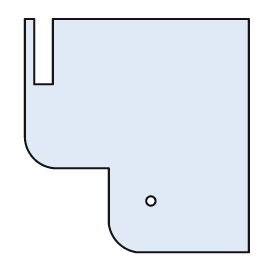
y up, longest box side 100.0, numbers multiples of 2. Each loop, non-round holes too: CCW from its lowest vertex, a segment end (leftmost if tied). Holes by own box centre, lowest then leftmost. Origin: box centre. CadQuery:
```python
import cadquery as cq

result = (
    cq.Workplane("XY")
    .moveTo(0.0, -50.0)
    .lineTo(48.0, -50.0)
    .lineTo(48.0, 50.0)
    .lineTo(-36.0, 50.0)
    .lineTo(-36.0, 22.0)
    .lineTo(-44.0, 22.0)
    .lineTo(-44.0, 50.0)
    .lineTo(-48.0, 50.0)
    .lineTo(-48.0, 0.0)
    .threePointArc((-44.0, -10.0), (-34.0, -14.0))
    .lineTo(-12.0, -14.0)
    .lineTo(-12.0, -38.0)
    .threePointArc((-8.0, -46.0), (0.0, -50.0))
    .close()
    .moveTo(6.0, -28.0)
    .circle(2.0)
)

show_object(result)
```